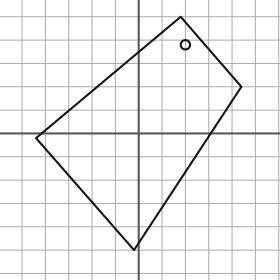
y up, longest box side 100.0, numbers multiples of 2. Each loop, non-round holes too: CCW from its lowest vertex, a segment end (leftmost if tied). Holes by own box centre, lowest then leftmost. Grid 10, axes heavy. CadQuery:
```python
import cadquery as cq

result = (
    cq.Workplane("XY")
    .moveTo(-2.0, -50.0)
    .lineTo(44.0, 20.0)
    .lineTo(18.0, 50.0)
    .lineTo(-44.0, -2.0)
    .close()
    .moveTo(20.0, 38.0)
    .circle(2.0)
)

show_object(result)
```